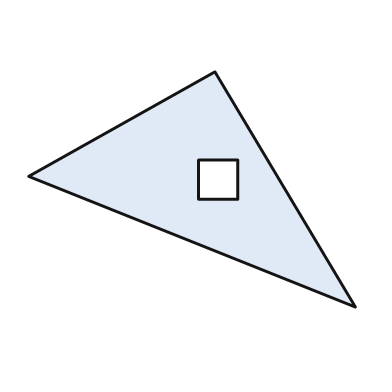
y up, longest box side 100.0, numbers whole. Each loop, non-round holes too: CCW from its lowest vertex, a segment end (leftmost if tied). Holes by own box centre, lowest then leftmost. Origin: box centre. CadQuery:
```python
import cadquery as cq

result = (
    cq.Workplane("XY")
    .moveTo(50.0, -36.0)
    .lineTo(7.0, 36.0)
    .lineTo(-50.0, 4.0)
    .close()
    .moveTo(2.0, -3.0)
    .lineTo(14.0, -3.0)
    .lineTo(14.0, 9.0)
    .lineTo(2.0, 9.0)
    .close()
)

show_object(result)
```